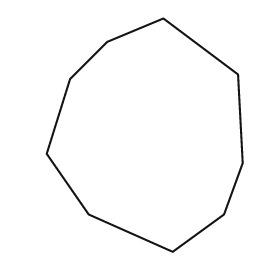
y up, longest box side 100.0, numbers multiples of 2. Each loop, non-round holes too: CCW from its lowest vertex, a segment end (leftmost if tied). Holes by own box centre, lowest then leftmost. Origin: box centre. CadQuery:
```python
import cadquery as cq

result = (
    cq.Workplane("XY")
    .moveTo(12.0, -50.0)
    .lineTo(34.0, -34.0)
    .lineTo(42.0, -12.0)
    .lineTo(40.0, 26.0)
    .lineTo(8.0, 50.0)
    .lineTo(-16.0, 40.0)
    .lineTo(-32.0, 24.0)
    .lineTo(-42.0, -8.0)
    .lineTo(-24.0, -34.0)
    .close()
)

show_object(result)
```